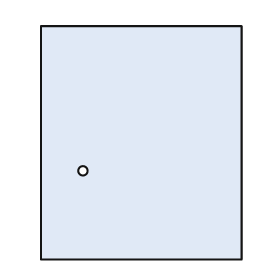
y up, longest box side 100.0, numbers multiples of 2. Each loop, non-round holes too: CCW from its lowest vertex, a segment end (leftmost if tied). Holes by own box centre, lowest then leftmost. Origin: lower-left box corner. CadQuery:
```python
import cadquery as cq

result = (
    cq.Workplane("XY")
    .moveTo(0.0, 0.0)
    .lineTo(86.0, 0.0)
    .lineTo(86.0, 100.0)
    .lineTo(0.0, 100.0)
    .close()
    .moveTo(18.0, 38.0)
    .circle(2.0)
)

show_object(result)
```